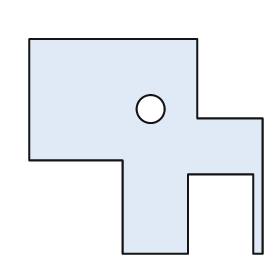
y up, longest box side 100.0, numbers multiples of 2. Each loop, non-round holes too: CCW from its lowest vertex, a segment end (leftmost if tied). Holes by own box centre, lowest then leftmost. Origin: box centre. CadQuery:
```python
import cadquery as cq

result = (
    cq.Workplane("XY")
    .moveTo(-10.0, -46.0)
    .lineTo(18.0, -46.0)
    .lineTo(18.0, -12.0)
    .lineTo(46.0, -12.0)
    .lineTo(46.0, -46.0)
    .lineTo(50.0, -46.0)
    .lineTo(50.0, 12.0)
    .lineTo(22.0, 12.0)
    .lineTo(22.0, 46.0)
    .lineTo(-50.0, 46.0)
    .lineTo(-50.0, -6.0)
    .lineTo(-10.0, -6.0)
    .close()
    .moveTo(2.0, 16.0)
    .circle(6.0)
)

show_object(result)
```